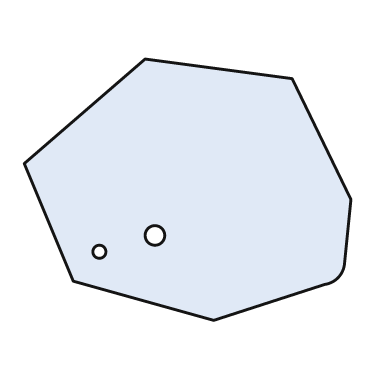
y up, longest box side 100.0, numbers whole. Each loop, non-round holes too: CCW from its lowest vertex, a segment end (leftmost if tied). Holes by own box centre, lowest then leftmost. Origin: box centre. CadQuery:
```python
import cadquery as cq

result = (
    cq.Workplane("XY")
    .moveTo(8.0, -40.0)
    .lineTo(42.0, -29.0)
    .threePointArc((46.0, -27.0), (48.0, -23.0))
    .lineTo(50.0, -3.0)
    .lineTo(32.0, 34.0)
    .lineTo(-13.0, 40.0)
    .lineTo(-50.0, 8.0)
    .lineTo(-35.0, -28.0)
    .close()
    .moveTo(-27.0, -19.0)
    .circle(2.0)
    .moveTo(-10.0, -14.0)
    .circle(3.0)
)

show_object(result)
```